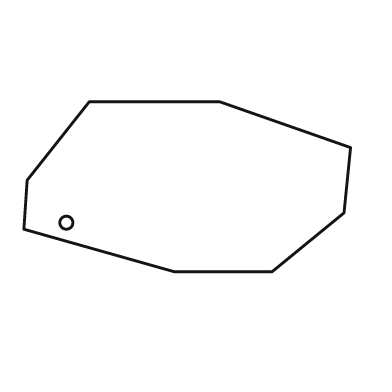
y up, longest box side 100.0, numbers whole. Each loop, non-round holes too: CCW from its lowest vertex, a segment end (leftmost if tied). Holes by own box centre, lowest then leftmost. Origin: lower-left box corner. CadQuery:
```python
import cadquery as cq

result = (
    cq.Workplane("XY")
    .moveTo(46.0, 0.0)
    .lineTo(76.0, 0.0)
    .lineTo(98.0, 18.0)
    .lineTo(100.0, 38.0)
    .lineTo(60.0, 52.0)
    .lineTo(20.0, 52.0)
    .lineTo(1.0, 28.0)
    .lineTo(0.0, 13.0)
    .close()
    .moveTo(13.0, 15.0)
    .circle(2.0)
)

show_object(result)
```